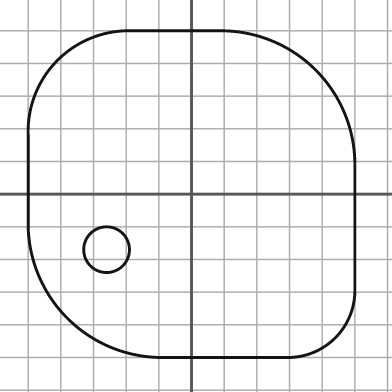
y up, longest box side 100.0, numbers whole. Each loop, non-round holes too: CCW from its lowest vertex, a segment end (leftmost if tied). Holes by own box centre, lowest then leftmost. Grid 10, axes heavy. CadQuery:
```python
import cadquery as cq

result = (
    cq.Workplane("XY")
    .moveTo(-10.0, -50.0)
    .lineTo(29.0, -50.0)
    .threePointArc((44.0, -44.0), (50.0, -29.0))
    .lineTo(50.0, 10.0)
    .threePointArc((38.0, 38.0), (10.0, 50.0))
    .lineTo(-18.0, 50.0)
    .threePointArc((-41.0, 41.0), (-50.0, 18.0))
    .lineTo(-50.0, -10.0)
    .threePointArc((-38.0, -38.0), (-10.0, -50.0))
    .close()
    .moveTo(-26.0, -17.0)
    .circle(7.0)
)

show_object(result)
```